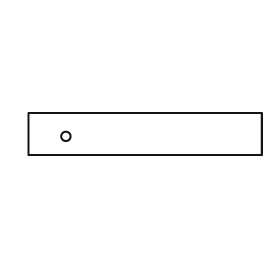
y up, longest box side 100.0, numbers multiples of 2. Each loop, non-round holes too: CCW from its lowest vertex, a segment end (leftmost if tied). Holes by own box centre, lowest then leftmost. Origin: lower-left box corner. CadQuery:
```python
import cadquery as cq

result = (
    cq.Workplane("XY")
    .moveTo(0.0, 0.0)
    .lineTo(100.0, 0.0)
    .lineTo(100.0, 18.0)
    .lineTo(0.0, 18.0)
    .close()
    .moveTo(16.0, 8.0)
    .circle(2.0)
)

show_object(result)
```